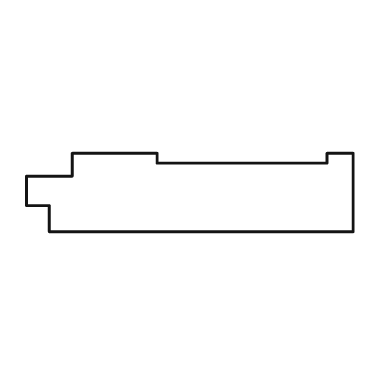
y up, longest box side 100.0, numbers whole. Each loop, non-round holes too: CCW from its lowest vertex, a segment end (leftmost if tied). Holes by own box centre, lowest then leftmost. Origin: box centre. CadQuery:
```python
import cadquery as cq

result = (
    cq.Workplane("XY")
    .moveTo(-43.0, -12.0)
    .lineTo(50.0, -12.0)
    .lineTo(50.0, 12.0)
    .lineTo(42.0, 12.0)
    .lineTo(42.0, 9.0)
    .lineTo(-10.0, 9.0)
    .lineTo(-10.0, 12.0)
    .lineTo(-36.0, 12.0)
    .lineTo(-36.0, 5.0)
    .lineTo(-50.0, 5.0)
    .lineTo(-50.0, -4.0)
    .lineTo(-43.0, -4.0)
    .close()
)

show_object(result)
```